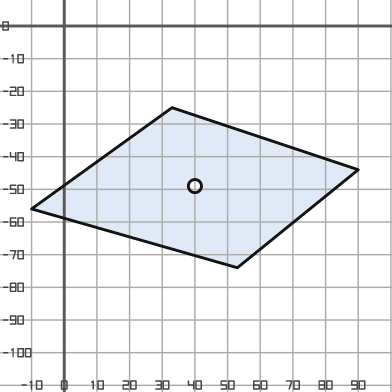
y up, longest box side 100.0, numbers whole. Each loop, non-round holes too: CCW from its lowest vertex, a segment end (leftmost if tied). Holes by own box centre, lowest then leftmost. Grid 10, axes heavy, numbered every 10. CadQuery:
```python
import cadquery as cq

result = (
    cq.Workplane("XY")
    .moveTo(53.0, -74.0)
    .lineTo(90.0, -44.0)
    .lineTo(33.0, -25.0)
    .lineTo(-10.0, -56.0)
    .close()
    .moveTo(40.0, -49.0)
    .circle(2.0)
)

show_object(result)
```